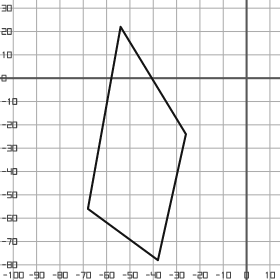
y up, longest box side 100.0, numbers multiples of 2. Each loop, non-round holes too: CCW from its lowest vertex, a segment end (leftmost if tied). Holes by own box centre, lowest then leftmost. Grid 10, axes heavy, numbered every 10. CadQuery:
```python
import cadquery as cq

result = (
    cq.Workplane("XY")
    .moveTo(-38.0, -78.0)
    .lineTo(-26.0, -24.0)
    .lineTo(-54.0, 22.0)
    .lineTo(-68.0, -56.0)
    .close()
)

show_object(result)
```